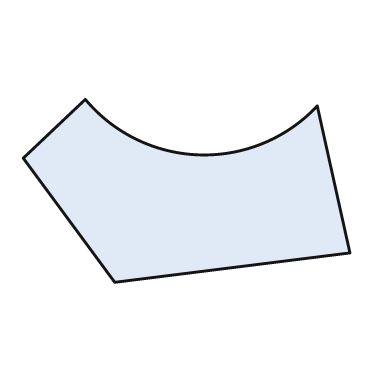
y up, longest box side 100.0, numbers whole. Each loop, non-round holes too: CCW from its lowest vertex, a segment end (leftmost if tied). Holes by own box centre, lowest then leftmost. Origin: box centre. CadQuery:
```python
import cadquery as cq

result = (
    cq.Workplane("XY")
    .moveTo(-22.0, -28.0)
    .lineTo(50.0, -19.0)
    .lineTo(40.0, 26.0)
    .threePointArc((4.0, 11.0), (-31.0, 28.0))
    .lineTo(-50.0, 10.0)
    .close()
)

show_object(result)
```